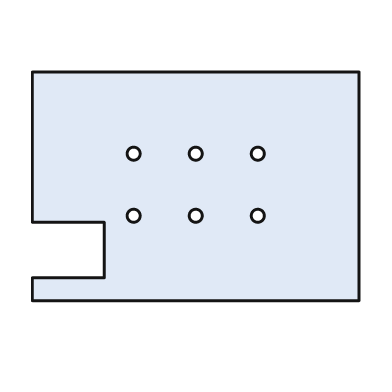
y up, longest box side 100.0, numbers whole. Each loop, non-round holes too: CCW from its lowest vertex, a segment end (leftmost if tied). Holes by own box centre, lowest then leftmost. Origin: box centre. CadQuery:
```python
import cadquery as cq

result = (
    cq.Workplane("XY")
    .moveTo(-50.0, -35.0)
    .lineTo(50.0, -35.0)
    .lineTo(50.0, 35.0)
    .lineTo(-50.0, 35.0)
    .lineTo(-50.0, -11.0)
    .lineTo(-28.0, -11.0)
    .lineTo(-28.0, -28.0)
    .lineTo(-50.0, -28.0)
    .close()
    .moveTo(-19.0, -9.0)
    .circle(2.0)
    .moveTo(0.0, -9.0)
    .circle(2.0)
    .moveTo(19.0, -9.0)
    .circle(2.0)
    .moveTo(-19.0, 10.0)
    .circle(2.0)
    .moveTo(0.0, 10.0)
    .circle(2.0)
    .moveTo(19.0, 10.0)
    .circle(2.0)
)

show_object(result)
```